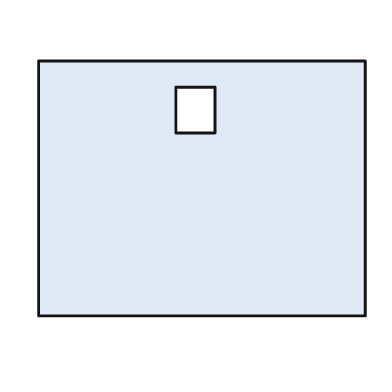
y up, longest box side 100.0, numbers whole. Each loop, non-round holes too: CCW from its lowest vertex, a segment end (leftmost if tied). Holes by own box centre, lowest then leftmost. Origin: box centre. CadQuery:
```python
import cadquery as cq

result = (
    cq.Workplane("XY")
    .moveTo(-50.0, -39.0)
    .lineTo(50.0, -39.0)
    .lineTo(50.0, 39.0)
    .lineTo(-50.0, 39.0)
    .close()
    .moveTo(-8.0, 17.0)
    .lineTo(4.0, 17.0)
    .lineTo(4.0, 31.0)
    .lineTo(-8.0, 31.0)
    .close()
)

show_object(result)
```